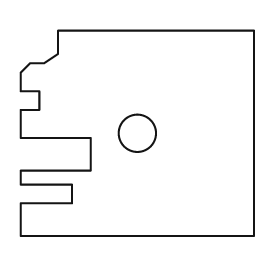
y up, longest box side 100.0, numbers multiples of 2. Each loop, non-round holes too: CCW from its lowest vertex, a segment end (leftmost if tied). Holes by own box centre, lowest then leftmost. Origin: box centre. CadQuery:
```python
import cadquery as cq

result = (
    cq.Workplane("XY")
    .moveTo(-50.0, -44.0)
    .lineTo(50.0, -44.0)
    .lineTo(50.0, 44.0)
    .lineTo(-34.0, 44.0)
    .lineTo(-34.0, 34.0)
    .lineTo(-40.0, 30.0)
    .lineTo(-46.0, 30.0)
    .lineTo(-50.0, 26.0)
    .lineTo(-50.0, 18.0)
    .lineTo(-42.0, 18.0)
    .lineTo(-42.0, 10.0)
    .lineTo(-50.0, 10.0)
    .lineTo(-50.0, -2.0)
    .lineTo(-20.0, -2.0)
    .lineTo(-20.0, -16.0)
    .lineTo(-50.0, -16.0)
    .lineTo(-50.0, -22.0)
    .lineTo(-28.0, -22.0)
    .lineTo(-28.0, -30.0)
    .lineTo(-50.0, -30.0)
    .close()
    .moveTo(0.0, 0.0)
    .circle(8.0)
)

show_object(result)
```